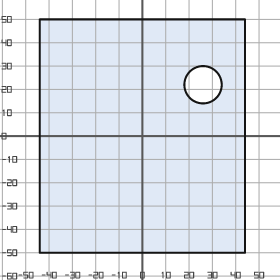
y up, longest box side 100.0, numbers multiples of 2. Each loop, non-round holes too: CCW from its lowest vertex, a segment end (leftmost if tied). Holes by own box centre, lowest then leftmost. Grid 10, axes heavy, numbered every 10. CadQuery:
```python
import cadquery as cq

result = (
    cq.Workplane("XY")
    .moveTo(-44.0, -50.0)
    .lineTo(44.0, -50.0)
    .lineTo(44.0, 50.0)
    .lineTo(-44.0, 50.0)
    .close()
    .moveTo(26.0, 22.0)
    .circle(8.0)
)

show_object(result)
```